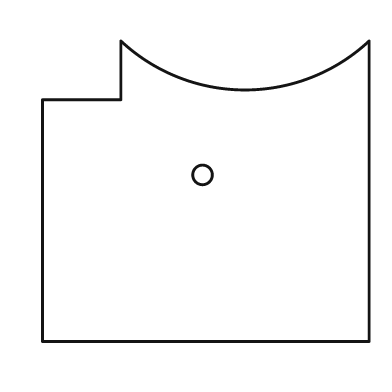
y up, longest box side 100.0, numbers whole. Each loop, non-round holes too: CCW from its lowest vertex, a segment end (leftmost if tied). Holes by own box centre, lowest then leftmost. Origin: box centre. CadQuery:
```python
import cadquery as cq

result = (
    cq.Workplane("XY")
    .moveTo(-50.0, -46.0)
    .lineTo(50.0, -46.0)
    .lineTo(50.0, 46.0)
    .threePointArc((12.0, 31.0), (-26.0, 46.0))
    .lineTo(-26.0, 28.0)
    .lineTo(-50.0, 28.0)
    .close()
    .moveTo(-1.0, 5.0)
    .circle(3.0)
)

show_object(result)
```